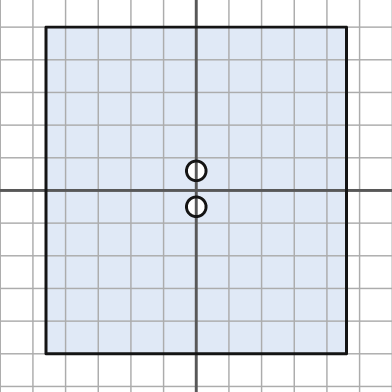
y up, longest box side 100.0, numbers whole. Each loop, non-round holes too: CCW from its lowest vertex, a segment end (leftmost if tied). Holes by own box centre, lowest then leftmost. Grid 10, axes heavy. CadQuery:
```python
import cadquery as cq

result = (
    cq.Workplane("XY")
    .moveTo(-46.0, -50.0)
    .lineTo(46.0, -50.0)
    .lineTo(46.0, 50.0)
    .lineTo(-46.0, 50.0)
    .close()
    .moveTo(0.0, -5.0)
    .circle(3.0)
    .moveTo(0.0, 6.0)
    .circle(3.0)
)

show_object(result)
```